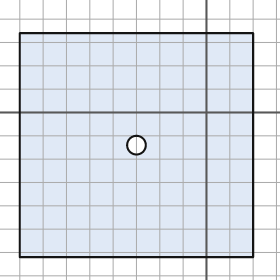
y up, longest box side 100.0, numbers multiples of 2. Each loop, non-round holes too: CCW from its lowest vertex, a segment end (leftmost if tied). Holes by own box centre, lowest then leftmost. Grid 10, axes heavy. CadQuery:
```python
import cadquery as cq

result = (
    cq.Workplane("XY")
    .moveTo(-80.0, -62.0)
    .lineTo(20.0, -62.0)
    .lineTo(20.0, 34.0)
    .lineTo(-80.0, 34.0)
    .close()
    .moveTo(-30.0, -14.0)
    .circle(4.0)
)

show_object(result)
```